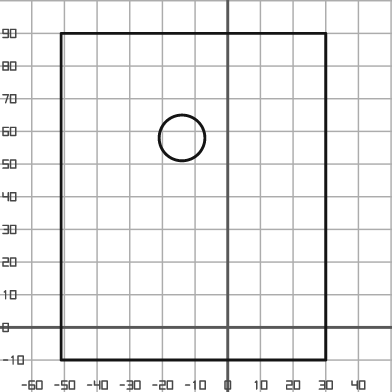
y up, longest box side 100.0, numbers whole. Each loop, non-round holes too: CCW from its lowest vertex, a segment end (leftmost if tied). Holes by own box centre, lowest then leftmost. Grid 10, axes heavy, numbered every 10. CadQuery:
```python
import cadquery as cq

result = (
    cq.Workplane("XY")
    .moveTo(-51.0, -10.0)
    .lineTo(30.0, -10.0)
    .lineTo(30.0, 90.0)
    .lineTo(-51.0, 90.0)
    .close()
    .moveTo(-14.0, 58.0)
    .circle(7.0)
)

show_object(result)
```